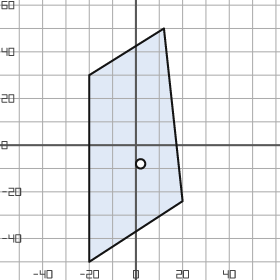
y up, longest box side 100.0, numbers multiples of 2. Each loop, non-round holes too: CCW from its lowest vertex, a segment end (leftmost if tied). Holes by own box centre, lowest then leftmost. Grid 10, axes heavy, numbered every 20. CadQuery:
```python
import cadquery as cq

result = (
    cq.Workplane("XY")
    .moveTo(-20.0, -50.0)
    .lineTo(20.0, -24.0)
    .lineTo(12.0, 50.0)
    .lineTo(-20.0, 30.0)
    .close()
    .moveTo(2.0, -8.0)
    .circle(2.0)
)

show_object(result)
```